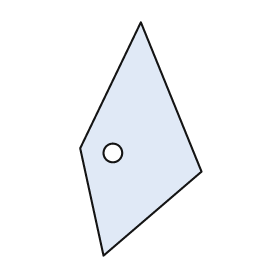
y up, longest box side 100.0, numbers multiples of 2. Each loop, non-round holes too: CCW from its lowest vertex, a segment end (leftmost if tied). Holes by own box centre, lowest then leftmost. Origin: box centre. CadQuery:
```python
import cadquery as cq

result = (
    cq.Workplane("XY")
    .moveTo(-16.0, -50.0)
    .lineTo(26.0, -14.0)
    .lineTo(0.0, 50.0)
    .lineTo(-26.0, -4.0)
    .close()
    .moveTo(-12.0, -6.0)
    .circle(4.0)
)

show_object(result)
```